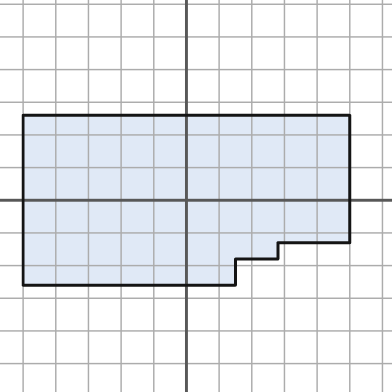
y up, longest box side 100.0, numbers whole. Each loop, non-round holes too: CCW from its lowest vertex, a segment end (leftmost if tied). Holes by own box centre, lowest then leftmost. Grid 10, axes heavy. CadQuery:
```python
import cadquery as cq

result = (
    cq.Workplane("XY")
    .moveTo(-50.0, -26.0)
    .lineTo(15.0, -26.0)
    .lineTo(15.0, -18.0)
    .lineTo(28.0, -18.0)
    .lineTo(28.0, -13.0)
    .lineTo(50.0, -13.0)
    .lineTo(50.0, 26.0)
    .lineTo(-50.0, 26.0)
    .close()
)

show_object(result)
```